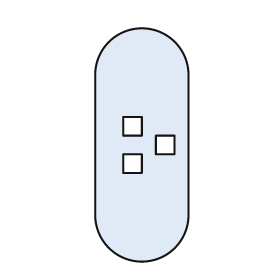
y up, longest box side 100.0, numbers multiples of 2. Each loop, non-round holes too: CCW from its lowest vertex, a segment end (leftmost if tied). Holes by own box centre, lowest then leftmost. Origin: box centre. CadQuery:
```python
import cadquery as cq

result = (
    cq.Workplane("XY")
    .moveTo(-20.0, -30.0)
    .threePointArc((0.0, -50.0), (20.0, -30.0))
    .lineTo(20.0, 30.0)
    .threePointArc((0.0, 50.0), (-20.0, 30.0))
    .close()
    .moveTo(-8.0, -12.0)
    .lineTo(0.0, -12.0)
    .lineTo(0.0, -4.0)
    .lineTo(-8.0, -4.0)
    .close()
    .moveTo(6.0, -4.0)
    .lineTo(14.0, -4.0)
    .lineTo(14.0, 4.0)
    .lineTo(6.0, 4.0)
    .close()
    .moveTo(-8.0, 4.0)
    .lineTo(0.0, 4.0)
    .lineTo(0.0, 12.0)
    .lineTo(-8.0, 12.0)
    .close()
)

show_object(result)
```